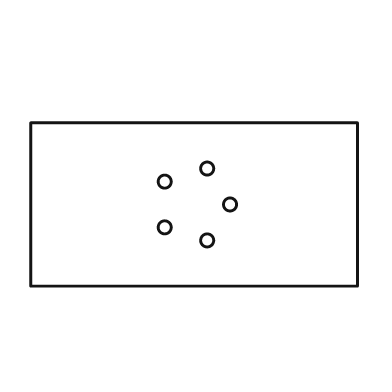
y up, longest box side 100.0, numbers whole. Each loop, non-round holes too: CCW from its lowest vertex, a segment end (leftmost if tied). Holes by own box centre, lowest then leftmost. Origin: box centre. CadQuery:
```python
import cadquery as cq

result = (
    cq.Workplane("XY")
    .moveTo(-50.0, -25.0)
    .lineTo(50.0, -25.0)
    .lineTo(50.0, 25.0)
    .lineTo(-50.0, 25.0)
    .close()
    .moveTo(4.0, -11.0)
    .circle(2.0)
    .moveTo(-9.0, -7.0)
    .circle(2.0)
    .moveTo(11.0, 0.0)
    .circle(2.0)
    .moveTo(-9.0, 7.0)
    .circle(2.0)
    .moveTo(4.0, 11.0)
    .circle(2.0)
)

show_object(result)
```